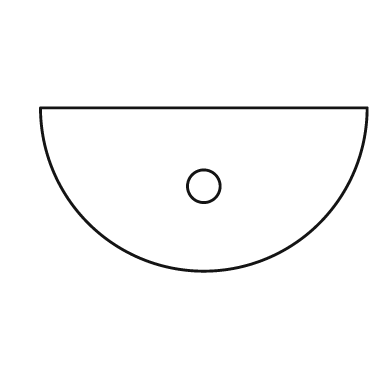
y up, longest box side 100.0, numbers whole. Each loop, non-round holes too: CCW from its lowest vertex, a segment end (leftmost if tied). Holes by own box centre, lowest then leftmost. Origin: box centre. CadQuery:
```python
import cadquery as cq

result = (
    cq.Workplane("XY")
    .moveTo(-50.0, 25.0)
    .threePointArc((0.0, -25.0), (50.0, 25.0))
    .close()
    .moveTo(0.0, 1.0)
    .circle(5.0)
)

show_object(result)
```